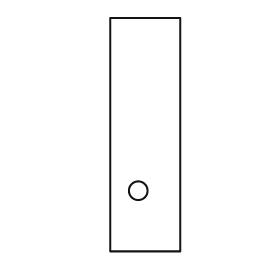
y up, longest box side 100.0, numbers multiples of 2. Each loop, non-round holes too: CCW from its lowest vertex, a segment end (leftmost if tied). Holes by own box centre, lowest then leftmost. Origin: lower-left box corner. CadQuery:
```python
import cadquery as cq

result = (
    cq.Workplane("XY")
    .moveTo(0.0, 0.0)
    .lineTo(30.0, 0.0)
    .lineTo(30.0, 100.0)
    .lineTo(0.0, 100.0)
    .close()
    .moveTo(12.0, 26.0)
    .circle(4.0)
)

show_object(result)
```